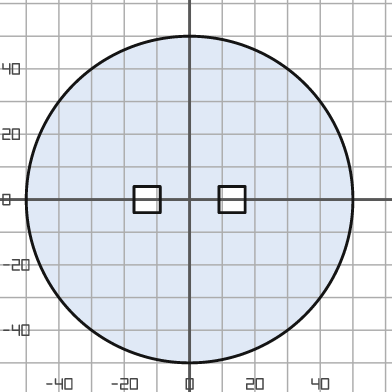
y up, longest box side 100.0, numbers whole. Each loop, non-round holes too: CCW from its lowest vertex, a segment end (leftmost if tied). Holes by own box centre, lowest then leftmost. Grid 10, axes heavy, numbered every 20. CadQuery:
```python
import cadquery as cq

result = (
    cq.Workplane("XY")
    .moveTo(0.0, 0.0)
    .circle(50.0)
    .moveTo(-17.0, -4.0)
    .lineTo(-9.0, -4.0)
    .lineTo(-9.0, 4.0)
    .lineTo(-17.0, 4.0)
    .close()
    .moveTo(9.0, -4.0)
    .lineTo(17.0, -4.0)
    .lineTo(17.0, 4.0)
    .lineTo(9.0, 4.0)
    .close()
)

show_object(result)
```